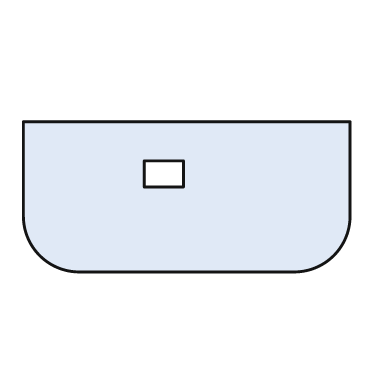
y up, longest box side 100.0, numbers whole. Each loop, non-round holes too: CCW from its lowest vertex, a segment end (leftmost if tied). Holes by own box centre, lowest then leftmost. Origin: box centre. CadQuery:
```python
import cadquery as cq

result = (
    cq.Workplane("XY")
    .moveTo(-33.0, -23.0)
    .lineTo(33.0, -23.0)
    .threePointArc((45.0, -18.0), (50.0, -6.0))
    .lineTo(50.0, 23.0)
    .lineTo(-50.0, 23.0)
    .lineTo(-50.0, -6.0)
    .threePointArc((-45.0, -18.0), (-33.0, -23.0))
    .close()
    .moveTo(-13.0, 3.0)
    .lineTo(-1.0, 3.0)
    .lineTo(-1.0, 11.0)
    .lineTo(-13.0, 11.0)
    .close()
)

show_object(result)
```